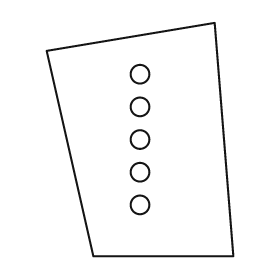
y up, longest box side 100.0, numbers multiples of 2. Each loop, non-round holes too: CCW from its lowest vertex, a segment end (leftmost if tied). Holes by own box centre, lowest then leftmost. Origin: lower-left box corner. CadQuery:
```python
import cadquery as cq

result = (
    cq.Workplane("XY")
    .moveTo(20.0, 0.0)
    .lineTo(80.0, 0.0)
    .lineTo(72.0, 100.0)
    .lineTo(0.0, 88.0)
    .close()
    .moveTo(40.0, 22.0)
    .circle(4.0)
    .moveTo(40.0, 36.0)
    .circle(4.0)
    .moveTo(40.0, 50.0)
    .circle(4.0)
    .moveTo(40.0, 64.0)
    .circle(4.0)
    .moveTo(40.0, 78.0)
    .circle(4.0)
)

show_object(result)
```